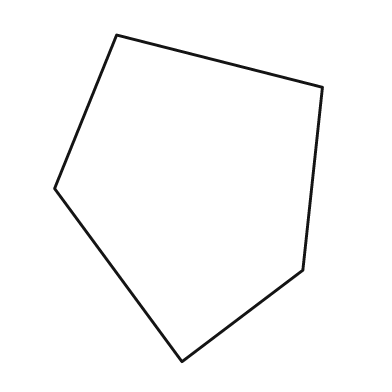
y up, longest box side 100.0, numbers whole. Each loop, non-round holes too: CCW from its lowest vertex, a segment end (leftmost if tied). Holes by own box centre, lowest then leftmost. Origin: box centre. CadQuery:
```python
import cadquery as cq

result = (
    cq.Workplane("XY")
    .moveTo(-2.0, -50.0)
    .lineTo(35.0, -22.0)
    .lineTo(41.0, 34.0)
    .lineTo(-22.0, 50.0)
    .lineTo(-41.0, 3.0)
    .close()
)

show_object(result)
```